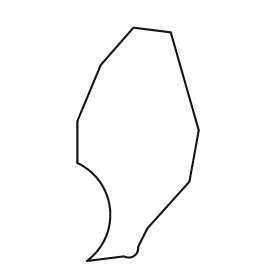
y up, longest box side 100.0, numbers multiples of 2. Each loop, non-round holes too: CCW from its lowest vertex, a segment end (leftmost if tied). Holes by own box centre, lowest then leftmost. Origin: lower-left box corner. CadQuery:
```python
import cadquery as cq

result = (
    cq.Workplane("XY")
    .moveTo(4.0, 0.0)
    .lineTo(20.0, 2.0)
    .threePointArc((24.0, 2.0), (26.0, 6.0))
    .lineTo(30.0, 14.0)
    .lineTo(48.0, 34.0)
    .lineTo(52.0, 56.0)
    .lineTo(40.0, 98.0)
    .lineTo(24.0, 100.0)
    .lineTo(10.0, 84.0)
    .lineTo(0.0, 60.0)
    .lineTo(0.0, 42.0)
    .threePointArc((14.0, 22.0), (4.0, 0.0))
    .close()
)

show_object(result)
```